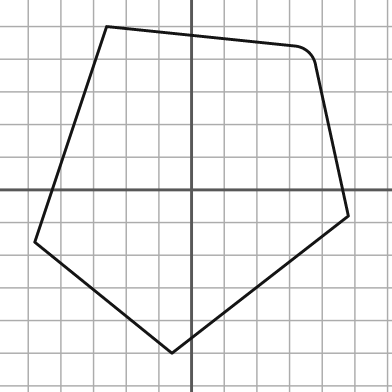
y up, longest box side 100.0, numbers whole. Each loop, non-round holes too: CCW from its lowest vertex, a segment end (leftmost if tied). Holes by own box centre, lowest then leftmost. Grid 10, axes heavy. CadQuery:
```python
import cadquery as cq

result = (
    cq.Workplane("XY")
    .moveTo(-6.0, -50.0)
    .lineTo(48.0, -8.0)
    .lineTo(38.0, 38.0)
    .threePointArc((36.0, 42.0), (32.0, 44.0))
    .lineTo(-26.0, 50.0)
    .lineTo(-48.0, -16.0)
    .close()
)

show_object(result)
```